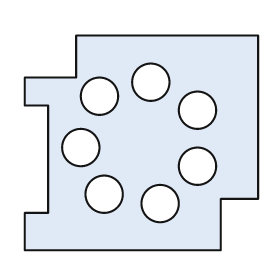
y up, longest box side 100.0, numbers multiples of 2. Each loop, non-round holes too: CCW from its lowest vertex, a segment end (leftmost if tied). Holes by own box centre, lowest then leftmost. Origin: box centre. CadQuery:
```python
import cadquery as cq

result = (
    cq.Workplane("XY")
    .moveTo(-50.0, -46.0)
    .lineTo(34.0, -46.0)
    .lineTo(34.0, -24.0)
    .lineTo(50.0, -24.0)
    .lineTo(50.0, 46.0)
    .lineTo(-28.0, 46.0)
    .lineTo(-28.0, 28.0)
    .lineTo(-50.0, 28.0)
    .lineTo(-50.0, 16.0)
    .lineTo(-40.0, 16.0)
    .lineTo(-40.0, -30.0)
    .lineTo(-50.0, -30.0)
    .close()
    .moveTo(8.0, -26.0)
    .circle(8.0)
    .moveTo(-16.0, -22.0)
    .circle(8.0)
    .moveTo(24.0, -10.0)
    .circle(8.0)
    .moveTo(-26.0, -2.0)
    .circle(8.0)
    .moveTo(24.0, 14.0)
    .circle(8.0)
    .moveTo(-18.0, 20.0)
    .circle(8.0)
    .moveTo(4.0, 26.0)
    .circle(8.0)
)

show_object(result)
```